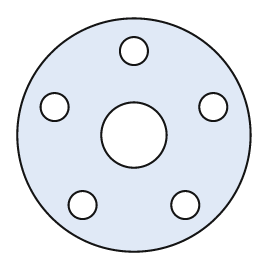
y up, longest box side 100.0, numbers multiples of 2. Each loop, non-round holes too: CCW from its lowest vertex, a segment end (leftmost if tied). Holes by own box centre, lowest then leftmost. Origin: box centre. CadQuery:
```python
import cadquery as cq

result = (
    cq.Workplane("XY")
    .moveTo(0.0, 0.0)
    .circle(50.0)
    .moveTo(-22.0, -30.0)
    .circle(6.0)
    .moveTo(22.0, -30.0)
    .circle(6.0)
    .moveTo(0.0, 0.0)
    .circle(14.0)
    .moveTo(-34.0, 12.0)
    .circle(6.0)
    .moveTo(34.0, 12.0)
    .circle(6.0)
    .moveTo(0.0, 36.0)
    .circle(6.0)
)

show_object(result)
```